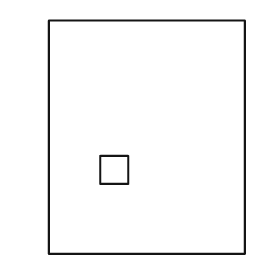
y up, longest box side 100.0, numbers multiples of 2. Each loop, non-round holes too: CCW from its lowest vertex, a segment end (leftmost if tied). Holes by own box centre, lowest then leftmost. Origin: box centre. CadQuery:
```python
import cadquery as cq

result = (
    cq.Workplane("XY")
    .moveTo(-42.0, -50.0)
    .lineTo(42.0, -50.0)
    .lineTo(42.0, 50.0)
    .lineTo(-42.0, 50.0)
    .close()
    .moveTo(-20.0, -20.0)
    .lineTo(-8.0, -20.0)
    .lineTo(-8.0, -8.0)
    .lineTo(-20.0, -8.0)
    .close()
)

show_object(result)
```